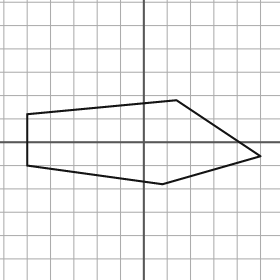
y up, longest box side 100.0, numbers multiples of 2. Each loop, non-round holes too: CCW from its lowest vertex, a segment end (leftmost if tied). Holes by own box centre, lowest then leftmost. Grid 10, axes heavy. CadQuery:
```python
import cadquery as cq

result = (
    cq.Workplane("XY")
    .moveTo(8.0, -18.0)
    .lineTo(50.0, -6.0)
    .lineTo(14.0, 18.0)
    .lineTo(-50.0, 12.0)
    .lineTo(-50.0, -10.0)
    .close()
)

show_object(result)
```